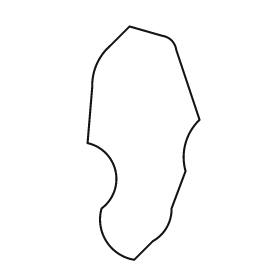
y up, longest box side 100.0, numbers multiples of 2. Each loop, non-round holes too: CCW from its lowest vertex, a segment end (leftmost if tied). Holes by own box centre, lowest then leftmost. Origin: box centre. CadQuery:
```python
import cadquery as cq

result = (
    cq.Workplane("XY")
    .moveTo(-4.0, -50.0)
    .lineTo(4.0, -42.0)
    .threePointArc((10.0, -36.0), (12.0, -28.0))
    .lineTo(18.0, -12.0)
    .threePointArc((18.0, 0.0), (24.0, 10.0))
    .lineTo(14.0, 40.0)
    .threePointArc((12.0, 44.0), (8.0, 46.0))
    .lineTo(-6.0, 50.0)
    .lineTo(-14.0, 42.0)
    .threePointArc((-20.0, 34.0), (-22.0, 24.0))
    .lineTo(-24.0, 0.0)
    .threePointArc((-12.0, -12.0), (-18.0, -28.0))
    .threePointArc((-16.0, -42.0), (-4.0, -50.0))
    .close()
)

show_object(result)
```